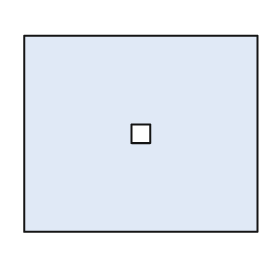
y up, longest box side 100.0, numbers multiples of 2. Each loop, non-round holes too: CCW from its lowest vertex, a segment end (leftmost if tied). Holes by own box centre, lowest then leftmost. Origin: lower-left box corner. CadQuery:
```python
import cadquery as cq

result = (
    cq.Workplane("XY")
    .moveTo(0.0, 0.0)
    .lineTo(100.0, 0.0)
    .lineTo(100.0, 84.0)
    .lineTo(0.0, 84.0)
    .close()
    .moveTo(46.0, 38.0)
    .lineTo(54.0, 38.0)
    .lineTo(54.0, 46.0)
    .lineTo(46.0, 46.0)
    .close()
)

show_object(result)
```